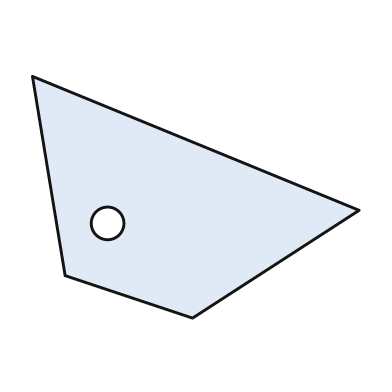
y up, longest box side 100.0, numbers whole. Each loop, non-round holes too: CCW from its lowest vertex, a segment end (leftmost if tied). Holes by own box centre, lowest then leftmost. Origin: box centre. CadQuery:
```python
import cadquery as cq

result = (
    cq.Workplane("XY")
    .moveTo(-1.0, -37.0)
    .lineTo(50.0, -4.0)
    .lineTo(-50.0, 37.0)
    .lineTo(-40.0, -24.0)
    .close()
    .moveTo(-27.0, -8.0)
    .circle(5.0)
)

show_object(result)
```